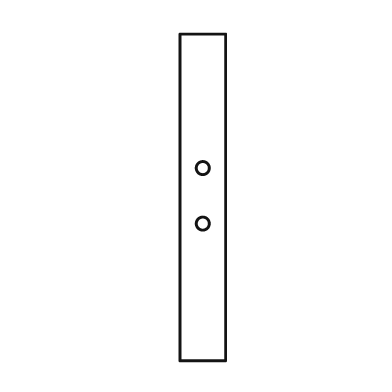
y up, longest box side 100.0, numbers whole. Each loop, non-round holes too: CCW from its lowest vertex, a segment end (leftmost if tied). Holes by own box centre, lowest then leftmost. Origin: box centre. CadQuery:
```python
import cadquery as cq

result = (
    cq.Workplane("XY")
    .moveTo(-7.0, -50.0)
    .lineTo(7.0, -50.0)
    .lineTo(7.0, 50.0)
    .lineTo(-7.0, 50.0)
    .close()
    .moveTo(0.0, -8.0)
    .circle(2.0)
    .moveTo(0.0, 9.0)
    .circle(2.0)
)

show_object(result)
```